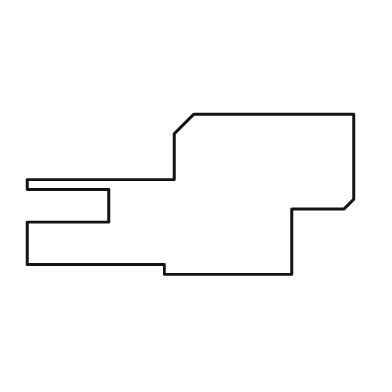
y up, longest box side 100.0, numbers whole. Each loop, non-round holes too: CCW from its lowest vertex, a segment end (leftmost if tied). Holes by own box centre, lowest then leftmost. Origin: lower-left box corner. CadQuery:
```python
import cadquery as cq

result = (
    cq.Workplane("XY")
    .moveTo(42.0, 0.0)
    .lineTo(81.0, 0.0)
    .lineTo(81.0, 20.0)
    .lineTo(97.0, 20.0)
    .lineTo(100.0, 23.0)
    .lineTo(100.0, 49.0)
    .lineTo(51.0, 49.0)
    .lineTo(45.0, 43.0)
    .lineTo(45.0, 29.0)
    .lineTo(0.0, 29.0)
    .lineTo(0.0, 26.0)
    .lineTo(25.0, 26.0)
    .lineTo(25.0, 16.0)
    .lineTo(0.0, 16.0)
    .lineTo(0.0, 3.0)
    .lineTo(42.0, 3.0)
    .close()
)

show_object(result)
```